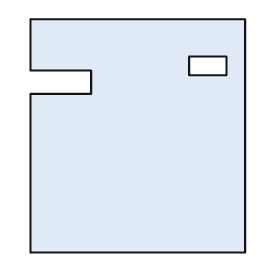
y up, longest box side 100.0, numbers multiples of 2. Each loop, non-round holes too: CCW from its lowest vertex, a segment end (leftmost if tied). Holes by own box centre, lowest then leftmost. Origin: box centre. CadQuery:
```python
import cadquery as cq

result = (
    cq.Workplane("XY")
    .moveTo(-46.0, -50.0)
    .lineTo(46.0, -50.0)
    .lineTo(46.0, 50.0)
    .lineTo(-46.0, 50.0)
    .lineTo(-46.0, 28.0)
    .lineTo(-20.0, 28.0)
    .lineTo(-20.0, 18.0)
    .lineTo(-46.0, 18.0)
    .close()
    .moveTo(22.0, 26.0)
    .lineTo(38.0, 26.0)
    .lineTo(38.0, 34.0)
    .lineTo(22.0, 34.0)
    .close()
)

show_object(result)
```